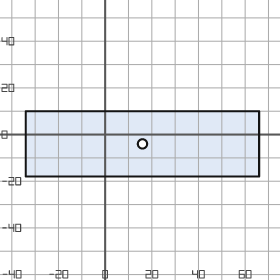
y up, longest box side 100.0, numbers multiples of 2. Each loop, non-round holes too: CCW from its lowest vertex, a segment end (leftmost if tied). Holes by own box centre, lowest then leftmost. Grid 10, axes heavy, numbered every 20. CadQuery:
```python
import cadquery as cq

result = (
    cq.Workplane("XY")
    .moveTo(-34.0, -18.0)
    .lineTo(66.0, -18.0)
    .lineTo(66.0, 10.0)
    .lineTo(-34.0, 10.0)
    .close()
    .moveTo(16.0, -4.0)
    .circle(2.0)
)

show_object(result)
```